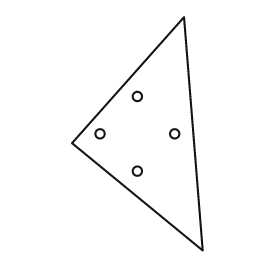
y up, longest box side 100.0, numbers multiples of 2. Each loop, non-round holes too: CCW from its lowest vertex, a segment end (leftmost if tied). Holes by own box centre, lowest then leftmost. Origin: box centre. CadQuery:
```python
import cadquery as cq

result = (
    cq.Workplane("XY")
    .moveTo(28.0, -50.0)
    .lineTo(20.0, 50.0)
    .lineTo(-28.0, -4.0)
    .close()
    .moveTo(0.0, -16.0)
    .circle(2.0)
    .moveTo(-16.0, 0.0)
    .circle(2.0)
    .moveTo(16.0, 0.0)
    .circle(2.0)
    .moveTo(0.0, 16.0)
    .circle(2.0)
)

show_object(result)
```